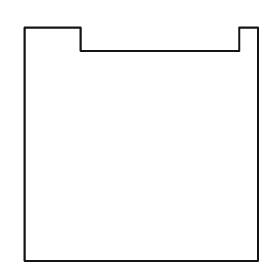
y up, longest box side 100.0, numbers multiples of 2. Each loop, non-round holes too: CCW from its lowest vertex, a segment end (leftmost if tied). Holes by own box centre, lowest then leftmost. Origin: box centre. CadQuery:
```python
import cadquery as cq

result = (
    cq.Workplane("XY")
    .moveTo(-50.0, -50.0)
    .lineTo(50.0, -50.0)
    .lineTo(50.0, 50.0)
    .lineTo(42.0, 50.0)
    .lineTo(42.0, 40.0)
    .lineTo(-26.0, 40.0)
    .lineTo(-26.0, 50.0)
    .lineTo(-50.0, 50.0)
    .close()
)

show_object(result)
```